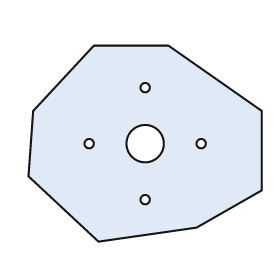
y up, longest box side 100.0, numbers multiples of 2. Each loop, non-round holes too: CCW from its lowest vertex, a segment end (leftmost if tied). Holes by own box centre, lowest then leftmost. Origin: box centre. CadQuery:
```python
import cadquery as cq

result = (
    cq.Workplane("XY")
    .moveTo(-20.0, -42.0)
    .lineTo(22.0, -36.0)
    .lineTo(50.0, -20.0)
    .lineTo(50.0, 14.0)
    .lineTo(10.0, 42.0)
    .lineTo(-22.0, 42.0)
    .lineTo(-48.0, 14.0)
    .lineTo(-50.0, -14.0)
    .close()
    .moveTo(0.0, -24.0)
    .circle(2.0)
    .moveTo(-24.0, 0.0)
    .circle(2.0)
    .moveTo(0.0, 0.0)
    .circle(8.0)
    .moveTo(24.0, 0.0)
    .circle(2.0)
    .moveTo(0.0, 24.0)
    .circle(2.0)
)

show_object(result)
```